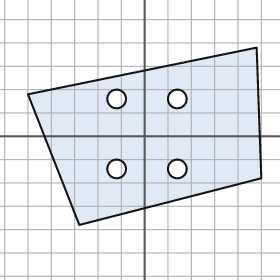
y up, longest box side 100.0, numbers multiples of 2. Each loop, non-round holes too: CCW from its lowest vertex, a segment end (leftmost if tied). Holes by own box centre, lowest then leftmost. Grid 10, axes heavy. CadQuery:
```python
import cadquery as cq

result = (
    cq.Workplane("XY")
    .moveTo(-28.0, -38.0)
    .lineTo(50.0, -18.0)
    .lineTo(48.0, 38.0)
    .lineTo(-50.0, 18.0)
    .close()
    .moveTo(-12.0, -14.0)
    .circle(4.0)
    .moveTo(14.0, -14.0)
    .circle(4.0)
    .moveTo(-12.0, 16.0)
    .circle(4.0)
    .moveTo(14.0, 16.0)
    .circle(4.0)
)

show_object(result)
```